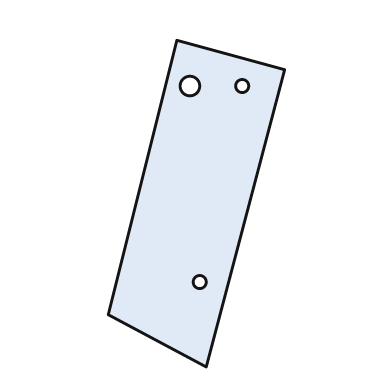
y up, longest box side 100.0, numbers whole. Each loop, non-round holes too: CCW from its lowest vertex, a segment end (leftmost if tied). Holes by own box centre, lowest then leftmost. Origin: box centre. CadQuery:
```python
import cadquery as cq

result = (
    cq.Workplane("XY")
    .moveTo(3.0, -50.0)
    .lineTo(27.0, 41.0)
    .lineTo(-6.0, 50.0)
    .lineTo(-27.0, -34.0)
    .close()
    .moveTo(1.0, -24.0)
    .circle(2.0)
    .moveTo(-2.0, 36.0)
    .circle(3.0)
    .moveTo(14.0, 36.0)
    .circle(2.0)
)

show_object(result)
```